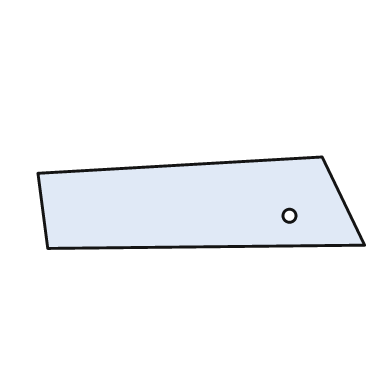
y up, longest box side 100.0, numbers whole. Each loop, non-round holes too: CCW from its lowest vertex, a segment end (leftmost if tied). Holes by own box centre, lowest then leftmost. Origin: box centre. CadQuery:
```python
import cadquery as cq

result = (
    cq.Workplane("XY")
    .moveTo(-47.0, -14.0)
    .lineTo(50.0, -13.0)
    .lineTo(37.0, 14.0)
    .lineTo(-50.0, 9.0)
    .close()
    .moveTo(27.0, -4.0)
    .circle(2.0)
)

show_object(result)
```